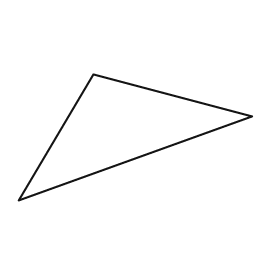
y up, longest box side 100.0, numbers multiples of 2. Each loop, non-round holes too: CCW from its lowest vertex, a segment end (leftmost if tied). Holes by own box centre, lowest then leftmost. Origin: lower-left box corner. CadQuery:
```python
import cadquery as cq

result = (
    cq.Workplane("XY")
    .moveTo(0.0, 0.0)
    .lineTo(100.0, 36.0)
    .lineTo(32.0, 54.0)
    .close()
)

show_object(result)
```